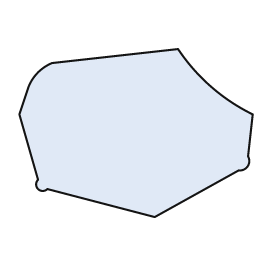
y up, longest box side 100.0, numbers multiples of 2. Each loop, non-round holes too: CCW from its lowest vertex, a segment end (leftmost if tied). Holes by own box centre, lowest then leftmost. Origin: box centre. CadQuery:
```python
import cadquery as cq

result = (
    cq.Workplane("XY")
    .moveTo(8.0, -36.0)
    .lineTo(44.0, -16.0)
    .threePointArc((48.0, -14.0), (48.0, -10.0))
    .lineTo(50.0, 8.0)
    .threePointArc((32.0, 20.0), (18.0, 36.0))
    .lineTo(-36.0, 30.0)
    .threePointArc((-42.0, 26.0), (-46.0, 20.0))
    .lineTo(-50.0, 8.0)
    .lineTo(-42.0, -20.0)
    .threePointArc((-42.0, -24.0), (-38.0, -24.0))
    .close()
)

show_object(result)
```